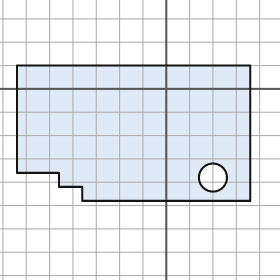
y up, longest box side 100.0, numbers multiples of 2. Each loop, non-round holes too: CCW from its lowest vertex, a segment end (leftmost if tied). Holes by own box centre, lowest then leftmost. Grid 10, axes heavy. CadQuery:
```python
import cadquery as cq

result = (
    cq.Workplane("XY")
    .moveTo(-36.0, -48.0)
    .lineTo(36.0, -48.0)
    .lineTo(36.0, 10.0)
    .lineTo(-64.0, 10.0)
    .lineTo(-64.0, -36.0)
    .lineTo(-46.0, -36.0)
    .lineTo(-46.0, -42.0)
    .lineTo(-36.0, -42.0)
    .close()
    .moveTo(20.0, -38.0)
    .circle(6.0)
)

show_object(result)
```